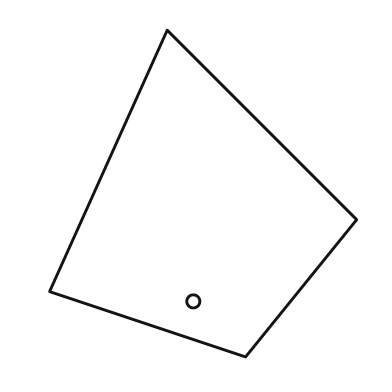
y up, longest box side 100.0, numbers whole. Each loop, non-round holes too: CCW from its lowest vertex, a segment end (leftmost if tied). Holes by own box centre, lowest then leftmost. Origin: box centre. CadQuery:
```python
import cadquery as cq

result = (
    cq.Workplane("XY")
    .moveTo(13.0, -50.0)
    .lineTo(47.0, -8.0)
    .lineTo(-11.0, 50.0)
    .lineTo(-47.0, -30.0)
    .close()
    .moveTo(-3.0, -33.0)
    .circle(2.0)
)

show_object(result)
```